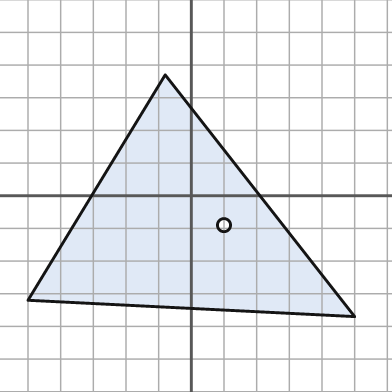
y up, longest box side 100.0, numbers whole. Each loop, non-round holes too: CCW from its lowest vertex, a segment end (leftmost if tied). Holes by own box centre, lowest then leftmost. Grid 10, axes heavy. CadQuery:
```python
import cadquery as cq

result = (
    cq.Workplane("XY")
    .moveTo(50.0, -37.0)
    .lineTo(-8.0, 37.0)
    .lineTo(-50.0, -32.0)
    .close()
    .moveTo(10.0, -9.0)
    .circle(2.0)
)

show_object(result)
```